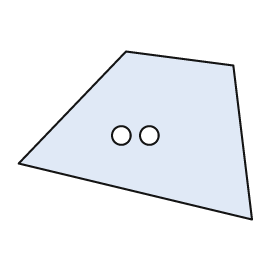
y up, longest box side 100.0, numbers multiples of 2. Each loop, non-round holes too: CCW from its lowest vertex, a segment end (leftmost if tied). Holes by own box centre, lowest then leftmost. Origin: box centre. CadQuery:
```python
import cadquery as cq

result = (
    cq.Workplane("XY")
    .moveTo(50.0, -36.0)
    .lineTo(42.0, 30.0)
    .lineTo(-4.0, 36.0)
    .lineTo(-50.0, -12.0)
    .close()
    .moveTo(-6.0, 0.0)
    .circle(4.0)
    .moveTo(6.0, 0.0)
    .circle(4.0)
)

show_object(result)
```